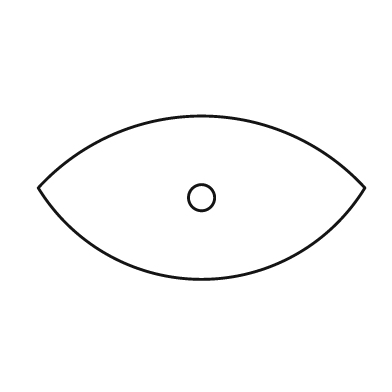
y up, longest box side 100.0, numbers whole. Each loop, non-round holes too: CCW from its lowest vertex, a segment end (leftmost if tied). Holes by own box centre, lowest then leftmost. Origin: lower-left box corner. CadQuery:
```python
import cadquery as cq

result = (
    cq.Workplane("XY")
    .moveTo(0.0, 28.0)
    .threePointArc((50.0, 0.0), (100.0, 28.0))
    .threePointArc((50.0, 50.0), (0.0, 28.0))
    .close()
    .moveTo(50.0, 25.0)
    .circle(4.0)
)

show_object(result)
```